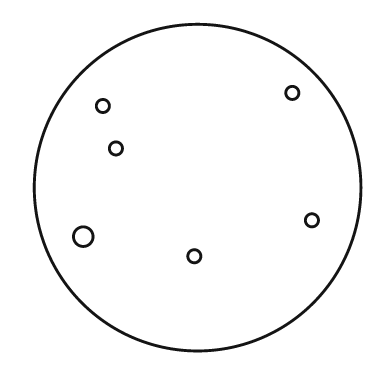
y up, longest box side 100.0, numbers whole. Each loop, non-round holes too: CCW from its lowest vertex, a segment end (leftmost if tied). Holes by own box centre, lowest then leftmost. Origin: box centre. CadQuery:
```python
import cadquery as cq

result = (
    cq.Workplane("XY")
    .moveTo(0.0, 0.0)
    .circle(50.0)
    .moveTo(-1.0, -21.0)
    .circle(2.0)
    .moveTo(-35.0, -15.0)
    .circle(3.0)
    .moveTo(35.0, -10.0)
    .circle(2.0)
    .moveTo(-25.0, 12.0)
    .circle(2.0)
    .moveTo(-29.0, 25.0)
    .circle(2.0)
    .moveTo(29.0, 29.0)
    .circle(2.0)
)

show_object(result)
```